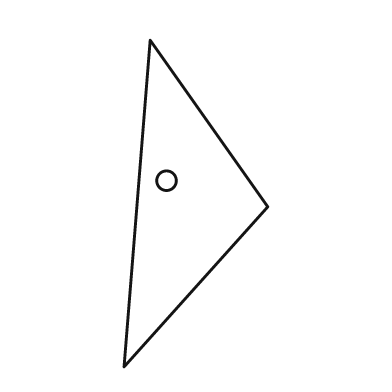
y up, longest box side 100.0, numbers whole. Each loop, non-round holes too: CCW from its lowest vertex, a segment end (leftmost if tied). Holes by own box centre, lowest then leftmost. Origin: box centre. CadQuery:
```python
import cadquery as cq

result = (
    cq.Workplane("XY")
    .moveTo(-22.0, -50.0)
    .lineTo(22.0, -1.0)
    .lineTo(-14.0, 50.0)
    .close()
    .moveTo(-9.0, 7.0)
    .circle(3.0)
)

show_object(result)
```